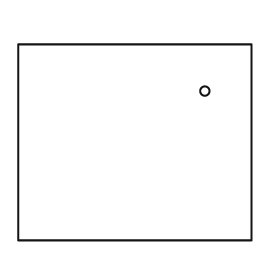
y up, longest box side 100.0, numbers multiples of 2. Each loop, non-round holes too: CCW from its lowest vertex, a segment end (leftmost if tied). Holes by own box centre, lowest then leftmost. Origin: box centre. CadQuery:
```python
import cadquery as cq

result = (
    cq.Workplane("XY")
    .moveTo(-50.0, -42.0)
    .lineTo(50.0, -42.0)
    .lineTo(50.0, 42.0)
    .lineTo(-50.0, 42.0)
    .close()
    .moveTo(30.0, 22.0)
    .circle(2.0)
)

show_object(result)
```